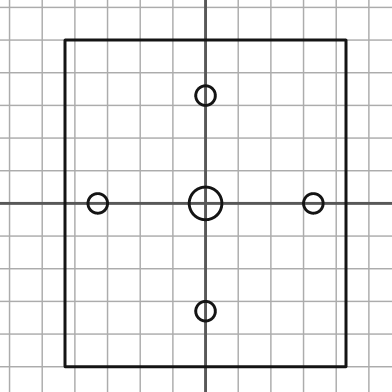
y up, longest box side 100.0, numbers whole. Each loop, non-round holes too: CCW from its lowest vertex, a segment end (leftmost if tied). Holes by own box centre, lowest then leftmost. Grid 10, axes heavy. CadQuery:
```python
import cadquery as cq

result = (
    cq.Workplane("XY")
    .moveTo(-43.0, -50.0)
    .lineTo(43.0, -50.0)
    .lineTo(43.0, 50.0)
    .lineTo(-43.0, 50.0)
    .close()
    .moveTo(0.0, -33.0)
    .circle(3.0)
    .moveTo(-33.0, 0.0)
    .circle(3.0)
    .moveTo(0.0, 0.0)
    .circle(5.0)
    .moveTo(33.0, 0.0)
    .circle(3.0)
    .moveTo(0.0, 33.0)
    .circle(3.0)
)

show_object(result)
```